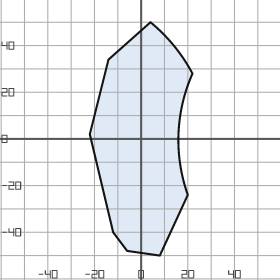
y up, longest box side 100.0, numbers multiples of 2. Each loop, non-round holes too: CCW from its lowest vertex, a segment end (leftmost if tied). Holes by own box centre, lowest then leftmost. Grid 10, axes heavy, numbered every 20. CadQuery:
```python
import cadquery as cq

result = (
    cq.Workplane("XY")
    .moveTo(8.0, -50.0)
    .lineTo(20.0, -24.0)
    .threePointArc((16.0, 2.0), (22.0, 28.0))
    .threePointArc((14.0, 40.0), (4.0, 50.0))
    .lineTo(-14.0, 34.0)
    .lineTo(-22.0, 2.0)
    .lineTo(-12.0, -40.0)
    .lineTo(-6.0, -48.0)
    .close()
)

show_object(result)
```